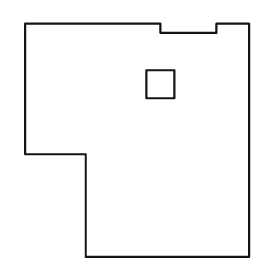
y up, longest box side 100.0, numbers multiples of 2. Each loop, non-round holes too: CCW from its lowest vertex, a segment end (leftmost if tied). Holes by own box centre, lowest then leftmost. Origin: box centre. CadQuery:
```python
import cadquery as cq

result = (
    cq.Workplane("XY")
    .moveTo(-22.0, -50.0)
    .lineTo(48.0, -50.0)
    .lineTo(48.0, 50.0)
    .lineTo(34.0, 50.0)
    .lineTo(34.0, 46.0)
    .lineTo(10.0, 46.0)
    .lineTo(10.0, 50.0)
    .lineTo(-48.0, 50.0)
    .lineTo(-48.0, -6.0)
    .lineTo(-22.0, -6.0)
    .close()
    .moveTo(4.0, 18.0)
    .lineTo(16.0, 18.0)
    .lineTo(16.0, 30.0)
    .lineTo(4.0, 30.0)
    .close()
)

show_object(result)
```